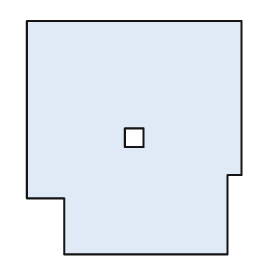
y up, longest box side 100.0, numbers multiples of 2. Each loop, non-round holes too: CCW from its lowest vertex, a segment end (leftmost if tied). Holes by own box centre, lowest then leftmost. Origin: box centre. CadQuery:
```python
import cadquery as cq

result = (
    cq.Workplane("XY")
    .moveTo(-30.0, -50.0)
    .lineTo(40.0, -50.0)
    .lineTo(40.0, -16.0)
    .lineTo(46.0, -16.0)
    .lineTo(46.0, 50.0)
    .lineTo(-46.0, 50.0)
    .lineTo(-46.0, -26.0)
    .lineTo(-30.0, -26.0)
    .close()
    .moveTo(-4.0, -4.0)
    .lineTo(4.0, -4.0)
    .lineTo(4.0, 4.0)
    .lineTo(-4.0, 4.0)
    .close()
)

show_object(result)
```